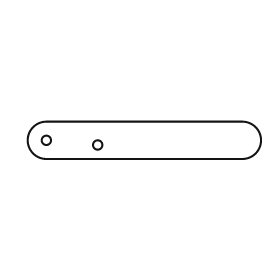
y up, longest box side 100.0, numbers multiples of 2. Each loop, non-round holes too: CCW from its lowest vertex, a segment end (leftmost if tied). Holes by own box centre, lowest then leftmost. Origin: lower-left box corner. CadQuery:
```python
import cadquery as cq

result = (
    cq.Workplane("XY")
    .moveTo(8.0, 0.0)
    .lineTo(92.0, 0.0)
    .threePointArc((100.0, 8.0), (92.0, 16.0))
    .lineTo(8.0, 16.0)
    .threePointArc((0.0, 8.0), (8.0, 0.0))
    .close()
    .moveTo(30.0, 6.0)
    .circle(2.0)
    .moveTo(8.0, 8.0)
    .circle(2.0)
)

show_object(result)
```